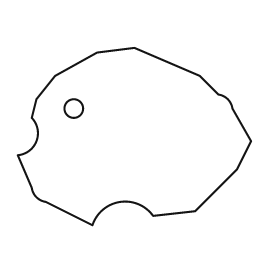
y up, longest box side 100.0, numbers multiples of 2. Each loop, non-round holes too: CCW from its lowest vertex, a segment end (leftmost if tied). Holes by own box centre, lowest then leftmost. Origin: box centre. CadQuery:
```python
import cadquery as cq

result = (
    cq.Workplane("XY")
    .moveTo(-18.0, -38.0)
    .threePointArc((-6.0, -28.0), (8.0, -34.0))
    .lineTo(26.0, -32.0)
    .lineTo(44.0, -14.0)
    .lineTo(50.0, -2.0)
    .lineTo(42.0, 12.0)
    .threePointArc((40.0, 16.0), (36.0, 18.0))
    .lineTo(28.0, 26.0)
    .lineTo(0.0, 38.0)
    .lineTo(-16.0, 36.0)
    .lineTo(-34.0, 26.0)
    .lineTo(-42.0, 16.0)
    .lineTo(-44.0, 8.0)
    .threePointArc((-42.0, -2.0), (-50.0, -8.0))
    .lineTo(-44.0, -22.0)
    .threePointArc((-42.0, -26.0), (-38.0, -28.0))
    .close()
    .moveTo(-26.0, 12.0)
    .circle(4.0)
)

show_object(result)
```